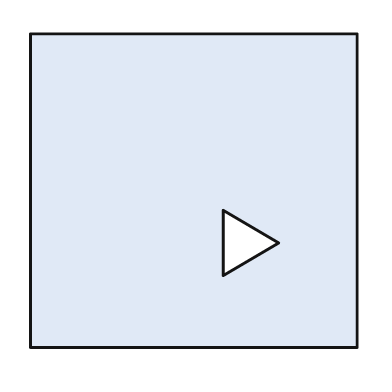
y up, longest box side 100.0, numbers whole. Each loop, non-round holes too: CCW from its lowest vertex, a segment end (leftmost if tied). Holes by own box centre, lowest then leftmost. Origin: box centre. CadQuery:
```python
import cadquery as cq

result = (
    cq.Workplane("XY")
    .moveTo(-50.0, -48.0)
    .lineTo(50.0, -48.0)
    .lineTo(50.0, 48.0)
    .lineTo(-50.0, 48.0)
    .close()
    .moveTo(9.0, -26.0)
    .lineTo(26.0, -16.0)
    .lineTo(9.0, -6.0)
    .close()
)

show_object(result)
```